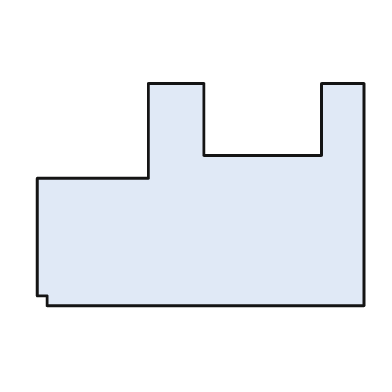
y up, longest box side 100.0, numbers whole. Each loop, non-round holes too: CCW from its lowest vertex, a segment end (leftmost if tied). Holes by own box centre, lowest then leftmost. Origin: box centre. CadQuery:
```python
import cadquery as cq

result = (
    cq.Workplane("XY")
    .moveTo(-47.0, -34.0)
    .lineTo(50.0, -34.0)
    .lineTo(50.0, 34.0)
    .lineTo(37.0, 34.0)
    .lineTo(37.0, 12.0)
    .lineTo(1.0, 12.0)
    .lineTo(1.0, 34.0)
    .lineTo(-16.0, 34.0)
    .lineTo(-16.0, 5.0)
    .lineTo(-50.0, 5.0)
    .lineTo(-50.0, -31.0)
    .lineTo(-47.0, -31.0)
    .close()
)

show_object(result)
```